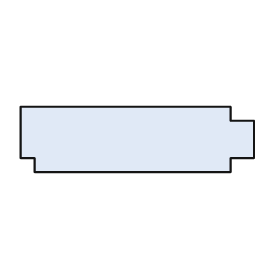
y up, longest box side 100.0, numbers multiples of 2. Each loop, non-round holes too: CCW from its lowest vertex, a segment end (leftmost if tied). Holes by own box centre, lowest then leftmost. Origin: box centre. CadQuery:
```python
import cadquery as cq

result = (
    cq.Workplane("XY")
    .moveTo(-44.0, -14.0)
    .lineTo(40.0, -14.0)
    .lineTo(40.0, -8.0)
    .lineTo(50.0, -8.0)
    .lineTo(50.0, 8.0)
    .lineTo(40.0, 8.0)
    .lineTo(40.0, 14.0)
    .lineTo(-50.0, 14.0)
    .lineTo(-50.0, -8.0)
    .lineTo(-44.0, -8.0)
    .close()
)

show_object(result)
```